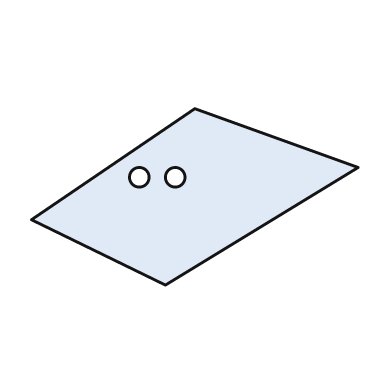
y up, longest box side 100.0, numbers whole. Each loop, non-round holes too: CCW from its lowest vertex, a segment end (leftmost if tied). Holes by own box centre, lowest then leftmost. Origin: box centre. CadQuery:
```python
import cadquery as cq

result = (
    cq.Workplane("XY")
    .moveTo(-9.0, -27.0)
    .lineTo(50.0, 9.0)
    .lineTo(0.0, 27.0)
    .lineTo(-50.0, -7.0)
    .close()
    .moveTo(-17.0, 6.0)
    .circle(3.0)
    .moveTo(-6.0, 6.0)
    .circle(3.0)
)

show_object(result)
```